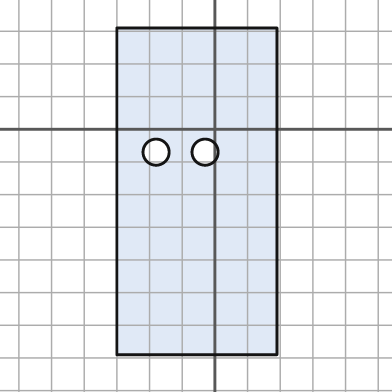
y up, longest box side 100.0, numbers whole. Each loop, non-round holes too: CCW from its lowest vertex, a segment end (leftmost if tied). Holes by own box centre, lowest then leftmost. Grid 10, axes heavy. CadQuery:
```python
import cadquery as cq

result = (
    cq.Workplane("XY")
    .moveTo(-30.0, -69.0)
    .lineTo(19.0, -69.0)
    .lineTo(19.0, 31.0)
    .lineTo(-30.0, 31.0)
    .close()
    .moveTo(-18.0, -7.0)
    .circle(4.0)
    .moveTo(-3.0, -7.0)
    .circle(4.0)
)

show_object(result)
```